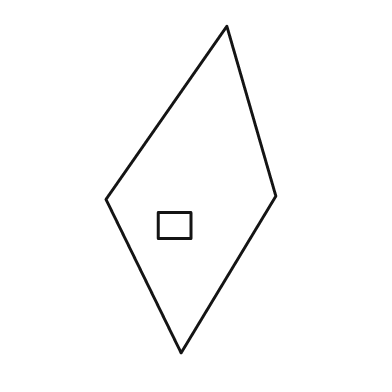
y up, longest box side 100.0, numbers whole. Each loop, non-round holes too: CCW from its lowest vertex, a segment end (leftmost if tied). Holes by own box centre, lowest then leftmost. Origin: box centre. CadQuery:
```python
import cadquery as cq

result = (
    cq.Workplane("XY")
    .moveTo(-3.0, -50.0)
    .lineTo(26.0, -2.0)
    .lineTo(11.0, 50.0)
    .lineTo(-26.0, -3.0)
    .close()
    .moveTo(-10.0, -15.0)
    .lineTo(0.0, -15.0)
    .lineTo(0.0, -7.0)
    .lineTo(-10.0, -7.0)
    .close()
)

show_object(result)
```